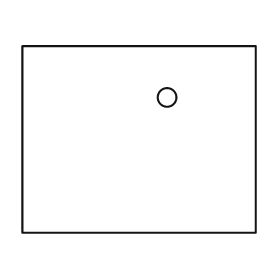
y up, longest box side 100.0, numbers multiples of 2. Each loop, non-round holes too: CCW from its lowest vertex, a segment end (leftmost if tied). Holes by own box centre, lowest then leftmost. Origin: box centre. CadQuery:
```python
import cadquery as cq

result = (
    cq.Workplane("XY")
    .moveTo(-50.0, -40.0)
    .lineTo(50.0, -40.0)
    .lineTo(50.0, 40.0)
    .lineTo(-50.0, 40.0)
    .close()
    .moveTo(12.0, 18.0)
    .circle(4.0)
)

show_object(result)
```